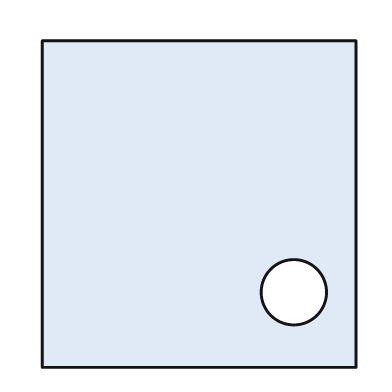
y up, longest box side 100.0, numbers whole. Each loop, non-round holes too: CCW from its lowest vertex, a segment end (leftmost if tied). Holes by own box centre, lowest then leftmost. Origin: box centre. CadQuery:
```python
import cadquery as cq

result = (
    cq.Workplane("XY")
    .moveTo(-48.0, -50.0)
    .lineTo(48.0, -50.0)
    .lineTo(48.0, 50.0)
    .lineTo(-48.0, 50.0)
    .close()
    .moveTo(29.0, -27.0)
    .circle(10.0)
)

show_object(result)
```